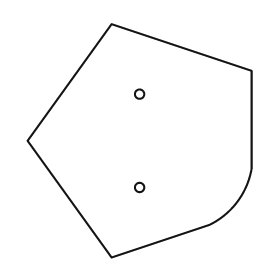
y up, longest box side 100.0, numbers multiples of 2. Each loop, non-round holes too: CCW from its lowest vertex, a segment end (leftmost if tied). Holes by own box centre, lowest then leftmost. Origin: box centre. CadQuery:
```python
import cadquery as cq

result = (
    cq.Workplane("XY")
    .moveTo(-12.0, -50.0)
    .lineTo(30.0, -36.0)
    .threePointArc((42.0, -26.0), (48.0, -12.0))
    .lineTo(48.0, 30.0)
    .lineTo(-12.0, 50.0)
    .lineTo(-48.0, 0.0)
    .close()
    .moveTo(0.0, -20.0)
    .circle(2.0)
    .moveTo(0.0, 20.0)
    .circle(2.0)
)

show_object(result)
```